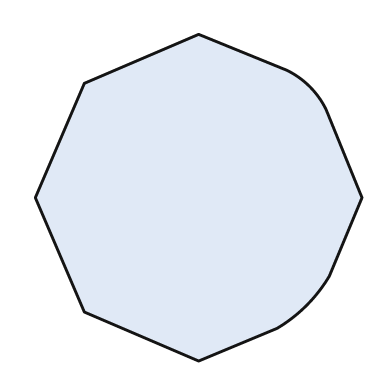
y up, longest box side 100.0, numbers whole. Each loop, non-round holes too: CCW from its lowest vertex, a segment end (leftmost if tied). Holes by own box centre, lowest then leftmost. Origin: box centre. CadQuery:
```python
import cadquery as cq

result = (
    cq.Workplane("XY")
    .moveTo(0.0, -50.0)
    .lineTo(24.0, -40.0)
    .threePointArc((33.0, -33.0), (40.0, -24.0))
    .lineTo(50.0, 0.0)
    .lineTo(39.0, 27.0)
    .threePointArc((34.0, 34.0), (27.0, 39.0))
    .lineTo(0.0, 50.0)
    .lineTo(-35.0, 35.0)
    .lineTo(-50.0, 0.0)
    .lineTo(-35.0, -35.0)
    .close()
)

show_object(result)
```